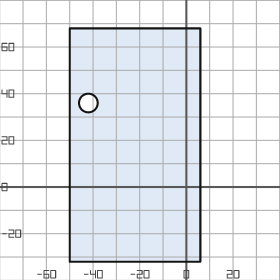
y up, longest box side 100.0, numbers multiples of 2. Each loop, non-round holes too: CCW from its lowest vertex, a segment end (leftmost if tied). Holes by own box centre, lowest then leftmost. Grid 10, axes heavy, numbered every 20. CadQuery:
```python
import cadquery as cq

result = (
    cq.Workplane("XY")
    .moveTo(-50.0, -32.0)
    .lineTo(6.0, -32.0)
    .lineTo(6.0, 68.0)
    .lineTo(-50.0, 68.0)
    .close()
    .moveTo(-42.0, 36.0)
    .circle(4.0)
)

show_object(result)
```